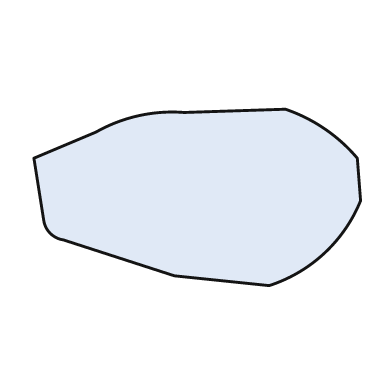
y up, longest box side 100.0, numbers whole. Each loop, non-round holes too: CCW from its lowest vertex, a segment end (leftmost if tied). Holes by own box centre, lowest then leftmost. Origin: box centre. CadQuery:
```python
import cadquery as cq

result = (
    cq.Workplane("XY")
    .moveTo(22.0, -27.0)
    .threePointArc((39.0, -17.0), (50.0, -1.0))
    .lineTo(49.0, 12.0)
    .threePointArc((39.0, 21.0), (27.0, 27.0))
    .lineTo(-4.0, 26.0)
    .threePointArc((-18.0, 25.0), (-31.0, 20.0))
    .lineTo(-50.0, 12.0)
    .lineTo(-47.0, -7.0)
    .threePointArc((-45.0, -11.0), (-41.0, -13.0))
    .lineTo(-7.0, -24.0)
    .close()
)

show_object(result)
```